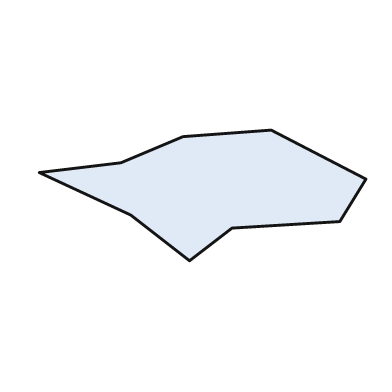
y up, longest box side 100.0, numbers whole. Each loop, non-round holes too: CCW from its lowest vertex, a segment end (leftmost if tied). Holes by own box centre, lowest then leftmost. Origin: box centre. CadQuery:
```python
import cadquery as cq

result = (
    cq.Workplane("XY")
    .moveTo(-4.0, -20.0)
    .lineTo(9.0, -10.0)
    .lineTo(42.0, -8.0)
    .lineTo(50.0, 5.0)
    .lineTo(21.0, 20.0)
    .lineTo(-6.0, 18.0)
    .lineTo(-25.0, 10.0)
    .lineTo(-50.0, 7.0)
    .lineTo(-22.0, -6.0)
    .close()
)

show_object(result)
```